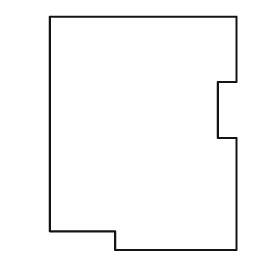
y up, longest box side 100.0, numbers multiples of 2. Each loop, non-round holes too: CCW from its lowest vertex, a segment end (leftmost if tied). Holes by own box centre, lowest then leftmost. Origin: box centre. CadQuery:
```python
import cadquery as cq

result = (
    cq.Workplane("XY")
    .moveTo(-12.0, -50.0)
    .lineTo(40.0, -50.0)
    .lineTo(40.0, -2.0)
    .lineTo(32.0, -2.0)
    .lineTo(32.0, 22.0)
    .lineTo(40.0, 22.0)
    .lineTo(40.0, 50.0)
    .lineTo(-40.0, 50.0)
    .lineTo(-40.0, -42.0)
    .lineTo(-12.0, -42.0)
    .close()
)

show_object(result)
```